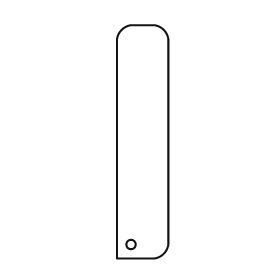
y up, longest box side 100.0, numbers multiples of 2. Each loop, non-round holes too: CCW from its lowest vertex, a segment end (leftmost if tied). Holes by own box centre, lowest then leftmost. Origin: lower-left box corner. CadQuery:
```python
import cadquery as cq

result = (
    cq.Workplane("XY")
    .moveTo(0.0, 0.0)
    .lineTo(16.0, 0.0)
    .threePointArc((20.0, 2.0), (22.0, 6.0))
    .lineTo(22.0, 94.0)
    .threePointArc((20.0, 98.0), (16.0, 100.0))
    .lineTo(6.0, 100.0)
    .threePointArc((2.0, 98.0), (0.0, 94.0))
    .close()
    .moveTo(6.0, 6.0)
    .circle(2.0)
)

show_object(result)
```